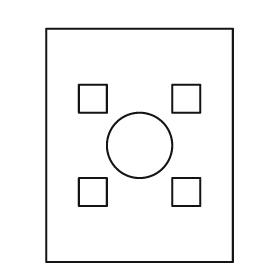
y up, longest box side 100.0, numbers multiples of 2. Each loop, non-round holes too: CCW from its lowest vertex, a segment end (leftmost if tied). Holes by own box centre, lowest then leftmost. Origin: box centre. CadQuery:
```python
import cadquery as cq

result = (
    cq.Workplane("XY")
    .moveTo(-40.0, -50.0)
    .lineTo(40.0, -50.0)
    .lineTo(40.0, 50.0)
    .lineTo(-40.0, 50.0)
    .close()
    .moveTo(-26.0, -26.0)
    .lineTo(-14.0, -26.0)
    .lineTo(-14.0, -14.0)
    .lineTo(-26.0, -14.0)
    .close()
    .moveTo(14.0, -26.0)
    .lineTo(26.0, -26.0)
    .lineTo(26.0, -14.0)
    .lineTo(14.0, -14.0)
    .close()
    .moveTo(0.0, 0.0)
    .circle(14.0)
    .moveTo(-26.0, 14.0)
    .lineTo(-14.0, 14.0)
    .lineTo(-14.0, 26.0)
    .lineTo(-26.0, 26.0)
    .close()
    .moveTo(14.0, 14.0)
    .lineTo(26.0, 14.0)
    .lineTo(26.0, 26.0)
    .lineTo(14.0, 26.0)
    .close()
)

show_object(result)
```